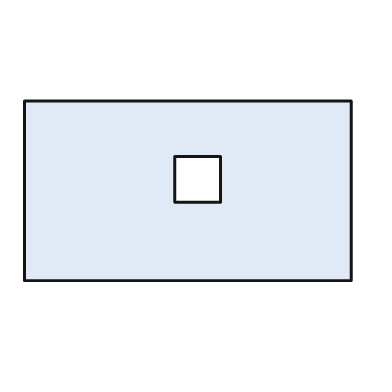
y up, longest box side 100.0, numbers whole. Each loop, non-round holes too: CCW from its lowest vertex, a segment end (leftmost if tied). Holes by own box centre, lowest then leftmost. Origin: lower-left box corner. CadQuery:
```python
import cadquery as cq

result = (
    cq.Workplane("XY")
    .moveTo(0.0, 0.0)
    .lineTo(100.0, 0.0)
    .lineTo(100.0, 55.0)
    .lineTo(0.0, 55.0)
    .close()
    .moveTo(46.0, 24.0)
    .lineTo(60.0, 24.0)
    .lineTo(60.0, 38.0)
    .lineTo(46.0, 38.0)
    .close()
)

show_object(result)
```